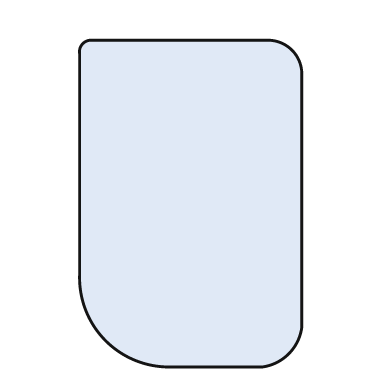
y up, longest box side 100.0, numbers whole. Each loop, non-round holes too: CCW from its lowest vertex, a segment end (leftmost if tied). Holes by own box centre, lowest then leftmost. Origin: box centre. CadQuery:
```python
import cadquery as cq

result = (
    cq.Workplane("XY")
    .moveTo(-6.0, -50.0)
    .lineTo(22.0, -50.0)
    .threePointArc((30.0, -46.0), (34.0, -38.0))
    .lineTo(34.0, 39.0)
    .threePointArc((31.0, 47.0), (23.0, 50.0))
    .lineTo(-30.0, 50.0)
    .threePointArc((-33.0, 49.0), (-34.0, 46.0))
    .lineTo(-34.0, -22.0)
    .threePointArc((-26.0, -42.0), (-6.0, -50.0))
    .close()
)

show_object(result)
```